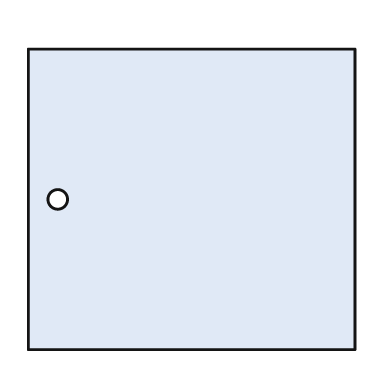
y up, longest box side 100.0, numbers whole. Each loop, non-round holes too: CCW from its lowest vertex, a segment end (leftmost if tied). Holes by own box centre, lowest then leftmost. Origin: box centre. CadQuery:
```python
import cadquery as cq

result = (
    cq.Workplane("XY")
    .moveTo(-50.0, -46.0)
    .lineTo(50.0, -46.0)
    .lineTo(50.0, 46.0)
    .lineTo(-50.0, 46.0)
    .close()
    .moveTo(-41.0, 0.0)
    .circle(3.0)
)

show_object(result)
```